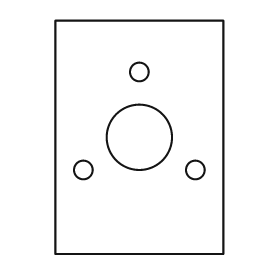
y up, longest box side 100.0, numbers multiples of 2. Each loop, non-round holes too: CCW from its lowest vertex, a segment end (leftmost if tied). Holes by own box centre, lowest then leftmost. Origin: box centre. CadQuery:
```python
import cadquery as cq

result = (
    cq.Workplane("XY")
    .moveTo(-36.0, -50.0)
    .lineTo(36.0, -50.0)
    .lineTo(36.0, 50.0)
    .lineTo(-36.0, 50.0)
    .close()
    .moveTo(-24.0, -14.0)
    .circle(4.0)
    .moveTo(24.0, -14.0)
    .circle(4.0)
    .moveTo(0.0, 0.0)
    .circle(14.0)
    .moveTo(0.0, 28.0)
    .circle(4.0)
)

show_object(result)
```